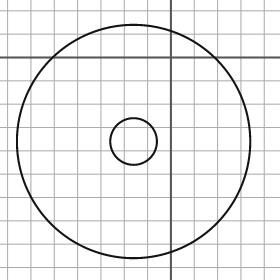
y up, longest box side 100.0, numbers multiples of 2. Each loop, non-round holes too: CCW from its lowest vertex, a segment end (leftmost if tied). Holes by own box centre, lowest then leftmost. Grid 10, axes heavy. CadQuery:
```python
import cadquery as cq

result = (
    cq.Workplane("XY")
    .moveTo(-16.0, -36.0)
    .circle(50.0)
    .moveTo(-16.0, -36.0)
    .circle(10.0)
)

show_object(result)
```